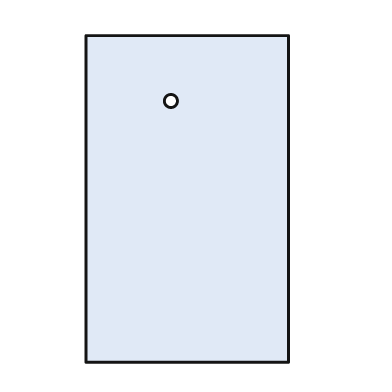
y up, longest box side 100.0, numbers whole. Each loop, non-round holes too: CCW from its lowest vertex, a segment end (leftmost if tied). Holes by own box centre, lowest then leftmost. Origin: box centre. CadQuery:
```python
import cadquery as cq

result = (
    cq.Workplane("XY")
    .moveTo(-31.0, -50.0)
    .lineTo(31.0, -50.0)
    .lineTo(31.0, 50.0)
    .lineTo(-31.0, 50.0)
    .close()
    .moveTo(-5.0, 30.0)
    .circle(2.0)
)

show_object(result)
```